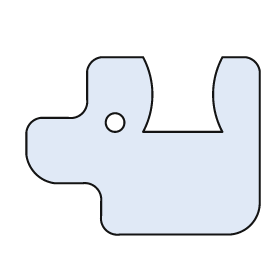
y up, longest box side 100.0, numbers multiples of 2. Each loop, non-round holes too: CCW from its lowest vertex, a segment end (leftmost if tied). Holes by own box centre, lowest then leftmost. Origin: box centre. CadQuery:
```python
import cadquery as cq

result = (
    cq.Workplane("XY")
    .moveTo(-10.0, -38.0)
    .lineTo(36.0, -38.0)
    .threePointArc((46.0, -34.0), (50.0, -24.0))
    .lineTo(50.0, 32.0)
    .threePointArc((48.0, 36.0), (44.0, 38.0))
    .lineTo(34.0, 38.0)
    .threePointArc((30.0, 22.0), (34.0, 6.0))
    .lineTo(0.0, 6.0)
    .threePointArc((4.0, 22.0), (0.0, 38.0))
    .lineTo(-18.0, 38.0)
    .threePointArc((-22.0, 36.0), (-24.0, 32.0))
    .lineTo(-24.0, 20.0)
    .threePointArc((-26.0, 14.0), (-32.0, 12.0))
    .lineTo(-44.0, 12.0)
    .threePointArc((-48.0, 10.0), (-50.0, 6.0))
    .lineTo(-50.0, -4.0)
    .threePointArc((-46.0, -12.0), (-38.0, -16.0))
    .lineTo(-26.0, -16.0)
    .threePointArc((-20.0, -18.0), (-18.0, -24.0))
    .lineTo(-18.0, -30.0)
    .threePointArc((-16.0, -36.0), (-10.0, -38.0))
    .close()
    .moveTo(-12.0, 10.0)
    .circle(4.0)
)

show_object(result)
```